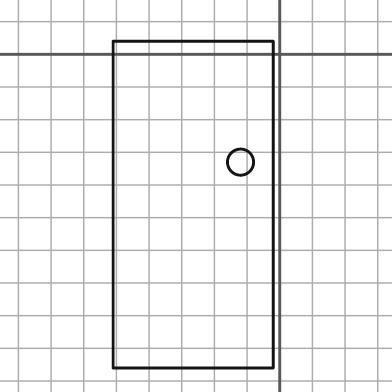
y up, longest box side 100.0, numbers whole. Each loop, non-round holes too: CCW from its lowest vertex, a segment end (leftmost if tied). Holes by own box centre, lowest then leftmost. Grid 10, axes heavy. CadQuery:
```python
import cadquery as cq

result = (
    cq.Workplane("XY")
    .moveTo(-51.0, -96.0)
    .lineTo(-2.0, -96.0)
    .lineTo(-2.0, 4.0)
    .lineTo(-51.0, 4.0)
    .close()
    .moveTo(-12.0, -33.0)
    .circle(4.0)
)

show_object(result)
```